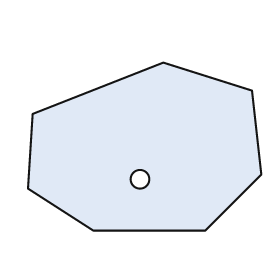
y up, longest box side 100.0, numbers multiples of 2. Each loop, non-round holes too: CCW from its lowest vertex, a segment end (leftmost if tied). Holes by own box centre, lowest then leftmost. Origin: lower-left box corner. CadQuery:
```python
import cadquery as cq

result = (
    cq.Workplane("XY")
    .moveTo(28.0, 0.0)
    .lineTo(76.0, 0.0)
    .lineTo(100.0, 24.0)
    .lineTo(96.0, 60.0)
    .lineTo(58.0, 72.0)
    .lineTo(2.0, 50.0)
    .lineTo(0.0, 18.0)
    .close()
    .moveTo(48.0, 22.0)
    .circle(4.0)
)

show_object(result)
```